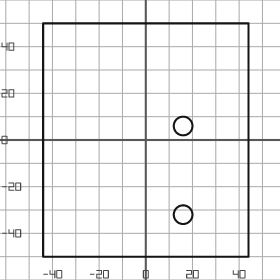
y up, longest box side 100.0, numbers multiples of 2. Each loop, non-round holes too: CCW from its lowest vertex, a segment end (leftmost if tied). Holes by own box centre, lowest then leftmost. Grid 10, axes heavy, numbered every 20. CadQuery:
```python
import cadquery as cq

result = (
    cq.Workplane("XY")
    .moveTo(-44.0, -50.0)
    .lineTo(44.0, -50.0)
    .lineTo(44.0, 50.0)
    .lineTo(-44.0, 50.0)
    .close()
    .moveTo(16.0, -32.0)
    .circle(4.0)
    .moveTo(16.0, 6.0)
    .circle(4.0)
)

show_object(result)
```